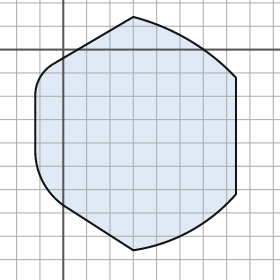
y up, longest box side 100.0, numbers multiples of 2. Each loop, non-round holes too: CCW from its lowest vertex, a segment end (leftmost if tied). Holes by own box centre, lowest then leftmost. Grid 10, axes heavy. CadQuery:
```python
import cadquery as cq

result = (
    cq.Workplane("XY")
    .moveTo(30.0, -86.0)
    .threePointArc((54.0, -78.0), (74.0, -62.0))
    .lineTo(74.0, -12.0)
    .threePointArc((54.0, 4.0), (30.0, 14.0))
    .lineTo(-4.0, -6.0)
    .threePointArc((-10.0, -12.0), (-12.0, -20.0))
    .lineTo(-12.0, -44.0)
    .threePointArc((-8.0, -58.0), (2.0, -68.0))
    .close()
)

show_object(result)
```